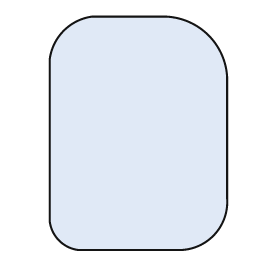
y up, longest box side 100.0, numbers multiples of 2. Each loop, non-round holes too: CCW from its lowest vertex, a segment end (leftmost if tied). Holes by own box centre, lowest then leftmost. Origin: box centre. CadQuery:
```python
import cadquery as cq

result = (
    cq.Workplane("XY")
    .moveTo(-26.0, -50.0)
    .lineTo(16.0, -50.0)
    .threePointArc((32.0, -44.0), (38.0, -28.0))
    .lineTo(38.0, 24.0)
    .threePointArc((30.0, 42.0), (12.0, 50.0))
    .lineTo(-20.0, 50.0)
    .threePointArc((-32.0, 44.0), (-38.0, 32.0))
    .lineTo(-38.0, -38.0)
    .threePointArc((-34.0, -46.0), (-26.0, -50.0))
    .close()
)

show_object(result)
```